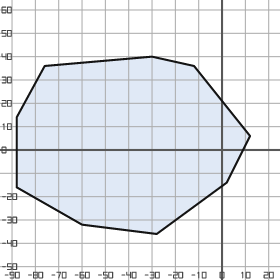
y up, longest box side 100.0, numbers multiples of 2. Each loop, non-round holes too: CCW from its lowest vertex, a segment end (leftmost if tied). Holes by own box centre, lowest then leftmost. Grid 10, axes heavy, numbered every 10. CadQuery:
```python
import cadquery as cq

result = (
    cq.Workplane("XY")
    .moveTo(-28.0, -36.0)
    .lineTo(2.0, -14.0)
    .lineTo(12.0, 6.0)
    .lineTo(-12.0, 36.0)
    .lineTo(-30.0, 40.0)
    .lineTo(-76.0, 36.0)
    .lineTo(-88.0, 14.0)
    .lineTo(-88.0, -16.0)
    .lineTo(-60.0, -32.0)
    .close()
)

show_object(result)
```